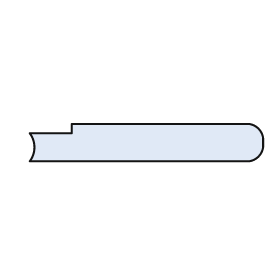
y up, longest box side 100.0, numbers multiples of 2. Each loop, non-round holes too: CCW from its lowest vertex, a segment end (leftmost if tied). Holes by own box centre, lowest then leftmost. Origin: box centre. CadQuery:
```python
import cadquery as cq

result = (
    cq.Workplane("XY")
    .moveTo(-50.0, -8.0)
    .lineTo(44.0, -8.0)
    .threePointArc((48.0, -6.0), (50.0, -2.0))
    .lineTo(50.0, 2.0)
    .threePointArc((48.0, 6.0), (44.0, 8.0))
    .lineTo(-32.0, 8.0)
    .lineTo(-32.0, 4.0)
    .lineTo(-50.0, 4.0)
    .threePointArc((-48.0, -2.0), (-50.0, -8.0))
    .close()
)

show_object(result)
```